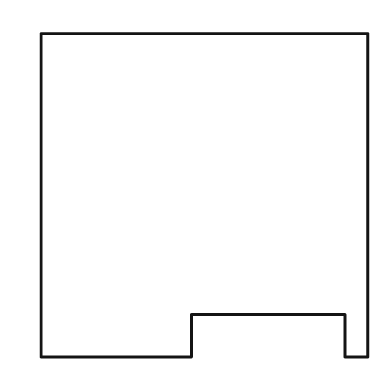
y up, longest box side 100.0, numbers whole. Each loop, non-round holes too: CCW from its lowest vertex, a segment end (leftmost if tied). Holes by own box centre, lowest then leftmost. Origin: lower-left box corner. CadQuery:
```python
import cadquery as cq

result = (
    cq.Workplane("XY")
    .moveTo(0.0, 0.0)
    .lineTo(46.0, 0.0)
    .lineTo(46.0, 13.0)
    .lineTo(93.0, 13.0)
    .lineTo(93.0, 0.0)
    .lineTo(100.0, 0.0)
    .lineTo(100.0, 99.0)
    .lineTo(0.0, 99.0)
    .close()
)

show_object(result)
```